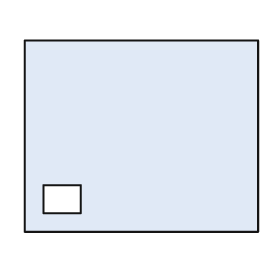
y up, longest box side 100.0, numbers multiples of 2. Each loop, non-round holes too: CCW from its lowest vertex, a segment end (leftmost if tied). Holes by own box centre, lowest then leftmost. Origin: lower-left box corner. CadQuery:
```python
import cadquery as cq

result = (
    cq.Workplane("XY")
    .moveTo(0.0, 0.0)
    .lineTo(100.0, 0.0)
    .lineTo(100.0, 82.0)
    .lineTo(0.0, 82.0)
    .close()
    .moveTo(8.0, 8.0)
    .lineTo(24.0, 8.0)
    .lineTo(24.0, 20.0)
    .lineTo(8.0, 20.0)
    .close()
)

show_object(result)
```